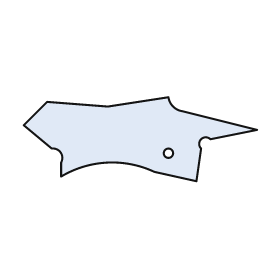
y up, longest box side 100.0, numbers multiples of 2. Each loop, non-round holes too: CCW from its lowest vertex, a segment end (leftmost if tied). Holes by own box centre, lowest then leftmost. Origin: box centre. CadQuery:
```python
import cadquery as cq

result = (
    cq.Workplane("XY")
    .moveTo(24.0, -18.0)
    .lineTo(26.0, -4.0)
    .threePointArc((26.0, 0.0), (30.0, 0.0))
    .lineTo(50.0, 4.0)
    .lineTo(18.0, 12.0)
    .threePointArc((14.0, 14.0), (12.0, 18.0))
    .lineTo(-14.0, 14.0)
    .lineTo(-40.0, 16.0)
    .lineTo(-50.0, 6.0)
    .lineTo(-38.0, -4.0)
    .threePointArc((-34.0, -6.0), (-34.0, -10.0))
    .lineTo(-34.0, -16.0)
    .threePointArc((-14.0, -10.0), (6.0, -14.0))
    .close()
    .moveTo(12.0, -6.0)
    .circle(2.0)
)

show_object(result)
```